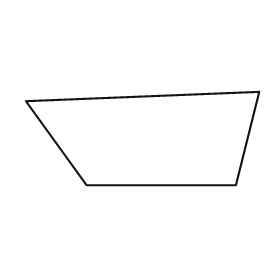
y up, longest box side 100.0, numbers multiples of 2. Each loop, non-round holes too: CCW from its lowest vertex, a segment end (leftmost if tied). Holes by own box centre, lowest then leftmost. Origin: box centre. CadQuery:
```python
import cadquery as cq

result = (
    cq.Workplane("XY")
    .moveTo(-24.0, -20.0)
    .lineTo(40.0, -20.0)
    .lineTo(50.0, 20.0)
    .lineTo(-50.0, 16.0)
    .close()
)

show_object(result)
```